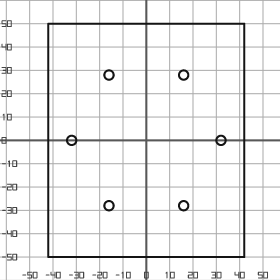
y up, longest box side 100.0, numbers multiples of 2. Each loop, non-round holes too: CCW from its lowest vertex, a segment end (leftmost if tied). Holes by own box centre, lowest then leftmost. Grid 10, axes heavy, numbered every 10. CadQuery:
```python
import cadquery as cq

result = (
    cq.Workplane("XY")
    .moveTo(-42.0, -50.0)
    .lineTo(42.0, -50.0)
    .lineTo(42.0, 50.0)
    .lineTo(-42.0, 50.0)
    .close()
    .moveTo(-16.0, -28.0)
    .circle(2.0)
    .moveTo(16.0, -28.0)
    .circle(2.0)
    .moveTo(-32.0, 0.0)
    .circle(2.0)
    .moveTo(32.0, 0.0)
    .circle(2.0)
    .moveTo(-16.0, 28.0)
    .circle(2.0)
    .moveTo(16.0, 28.0)
    .circle(2.0)
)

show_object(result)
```